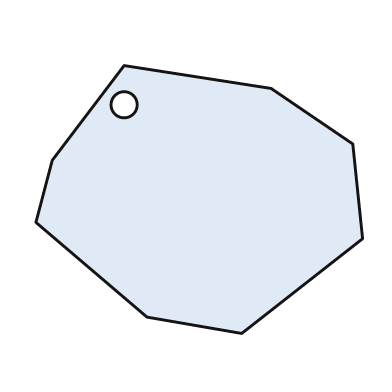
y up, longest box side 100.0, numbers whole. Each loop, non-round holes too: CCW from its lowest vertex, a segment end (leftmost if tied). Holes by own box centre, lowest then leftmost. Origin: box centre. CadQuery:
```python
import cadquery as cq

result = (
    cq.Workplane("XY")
    .moveTo(13.0, -41.0)
    .lineTo(50.0, -12.0)
    .lineTo(47.0, 17.0)
    .lineTo(22.0, 34.0)
    .lineTo(-23.0, 41.0)
    .lineTo(-45.0, 12.0)
    .lineTo(-50.0, -7.0)
    .lineTo(-16.0, -36.0)
    .close()
    .moveTo(-23.0, 29.0)
    .circle(4.0)
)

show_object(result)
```